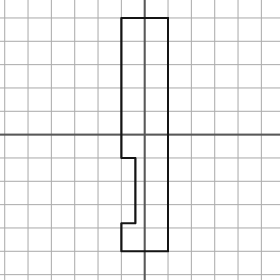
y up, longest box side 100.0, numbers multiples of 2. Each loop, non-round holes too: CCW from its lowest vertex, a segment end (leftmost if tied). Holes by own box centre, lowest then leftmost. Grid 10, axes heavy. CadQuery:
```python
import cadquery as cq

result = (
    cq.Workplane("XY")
    .moveTo(-10.0, -50.0)
    .lineTo(10.0, -50.0)
    .lineTo(10.0, 50.0)
    .lineTo(-10.0, 50.0)
    .lineTo(-10.0, -10.0)
    .lineTo(-4.0, -10.0)
    .lineTo(-4.0, -38.0)
    .lineTo(-10.0, -38.0)
    .close()
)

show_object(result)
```